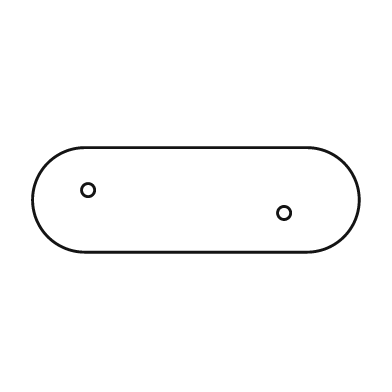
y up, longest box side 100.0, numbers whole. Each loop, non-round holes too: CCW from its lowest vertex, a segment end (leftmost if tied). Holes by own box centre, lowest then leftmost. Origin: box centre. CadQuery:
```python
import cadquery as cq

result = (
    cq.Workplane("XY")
    .moveTo(-34.0, -16.0)
    .lineTo(34.0, -16.0)
    .threePointArc((50.0, 0.0), (34.0, 16.0))
    .lineTo(-34.0, 16.0)
    .threePointArc((-50.0, 0.0), (-34.0, -16.0))
    .close()
    .moveTo(27.0, -4.0)
    .circle(2.0)
    .moveTo(-33.0, 3.0)
    .circle(2.0)
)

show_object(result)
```